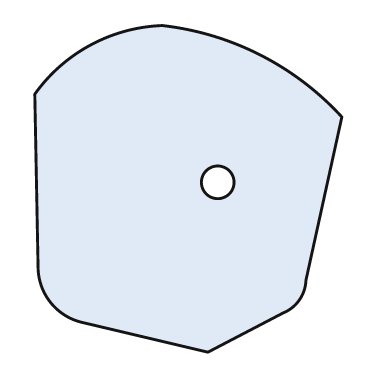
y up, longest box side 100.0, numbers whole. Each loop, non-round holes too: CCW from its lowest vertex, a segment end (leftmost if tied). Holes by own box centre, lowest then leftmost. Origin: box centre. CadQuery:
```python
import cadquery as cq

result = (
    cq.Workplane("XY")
    .moveTo(6.0, -50.0)
    .lineTo(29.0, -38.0)
    .threePointArc((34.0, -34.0), (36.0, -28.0))
    .lineTo(47.0, 22.0)
    .threePointArc((22.0, 41.0), (-8.0, 50.0))
    .threePointArc((-30.0, 44.0), (-47.0, 29.0))
    .lineTo(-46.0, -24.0)
    .threePointArc((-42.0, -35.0), (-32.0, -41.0))
    .close()
    .moveTo(9.0, 2.0)
    .circle(5.0)
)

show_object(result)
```